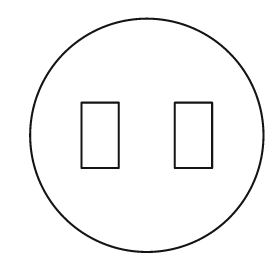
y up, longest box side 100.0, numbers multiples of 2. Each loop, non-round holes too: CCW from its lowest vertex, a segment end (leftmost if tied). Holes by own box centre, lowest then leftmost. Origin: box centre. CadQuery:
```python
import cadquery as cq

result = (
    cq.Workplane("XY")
    .moveTo(0.0, 0.0)
    .circle(50.0)
    .moveTo(-28.0, -14.0)
    .lineTo(-12.0, -14.0)
    .lineTo(-12.0, 14.0)
    .lineTo(-28.0, 14.0)
    .close()
    .moveTo(12.0, -14.0)
    .lineTo(28.0, -14.0)
    .lineTo(28.0, 14.0)
    .lineTo(12.0, 14.0)
    .close()
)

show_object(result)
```